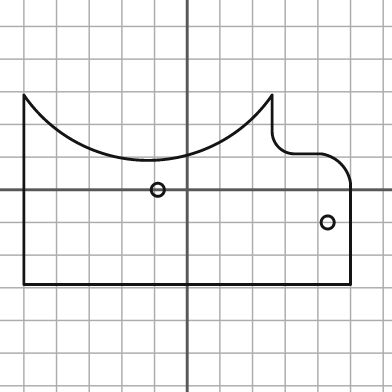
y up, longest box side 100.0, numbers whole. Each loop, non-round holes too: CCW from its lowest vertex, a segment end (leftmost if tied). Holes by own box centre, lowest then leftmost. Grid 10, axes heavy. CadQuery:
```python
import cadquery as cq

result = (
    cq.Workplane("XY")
    .moveTo(-50.0, -29.0)
    .lineTo(50.0, -29.0)
    .lineTo(50.0, 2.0)
    .threePointArc((47.0, 8.0), (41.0, 11.0))
    .lineTo(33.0, 11.0)
    .threePointArc((28.0, 13.0), (26.0, 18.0))
    .lineTo(26.0, 29.0)
    .threePointArc((-12.0, 9.0), (-50.0, 29.0))
    .close()
    .moveTo(43.0, -10.0)
    .circle(2.0)
    .moveTo(-9.0, 0.0)
    .circle(2.0)
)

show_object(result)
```